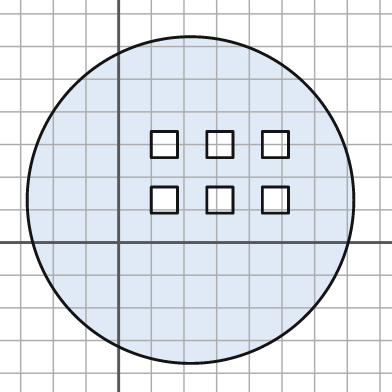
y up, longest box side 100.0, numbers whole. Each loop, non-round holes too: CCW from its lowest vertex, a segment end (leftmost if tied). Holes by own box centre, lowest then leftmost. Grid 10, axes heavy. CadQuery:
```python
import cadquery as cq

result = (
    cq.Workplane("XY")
    .moveTo(22.0, 13.0)
    .circle(50.0)
    .moveTo(10.0, 9.0)
    .lineTo(18.0, 9.0)
    .lineTo(18.0, 17.0)
    .lineTo(10.0, 17.0)
    .close()
    .moveTo(27.0, 9.0)
    .lineTo(35.0, 9.0)
    .lineTo(35.0, 17.0)
    .lineTo(27.0, 17.0)
    .close()
    .moveTo(44.0, 9.0)
    .lineTo(52.0, 9.0)
    .lineTo(52.0, 17.0)
    .lineTo(44.0, 17.0)
    .close()
    .moveTo(10.0, 26.0)
    .lineTo(18.0, 26.0)
    .lineTo(18.0, 34.0)
    .lineTo(10.0, 34.0)
    .close()
    .moveTo(27.0, 26.0)
    .lineTo(35.0, 26.0)
    .lineTo(35.0, 34.0)
    .lineTo(27.0, 34.0)
    .close()
    .moveTo(44.0, 26.0)
    .lineTo(52.0, 26.0)
    .lineTo(52.0, 34.0)
    .lineTo(44.0, 34.0)
    .close()
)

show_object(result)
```